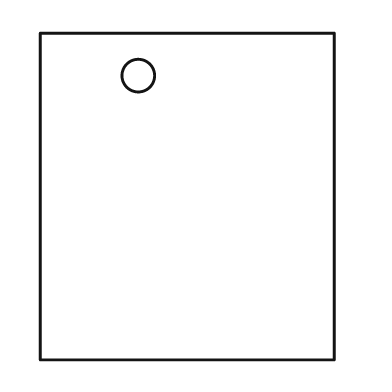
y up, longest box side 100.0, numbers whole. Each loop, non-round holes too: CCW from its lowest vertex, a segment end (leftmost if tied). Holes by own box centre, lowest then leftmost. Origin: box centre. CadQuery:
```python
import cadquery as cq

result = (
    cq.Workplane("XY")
    .moveTo(-45.0, -50.0)
    .lineTo(45.0, -50.0)
    .lineTo(45.0, 50.0)
    .lineTo(-45.0, 50.0)
    .close()
    .moveTo(-15.0, 37.0)
    .circle(5.0)
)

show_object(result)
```